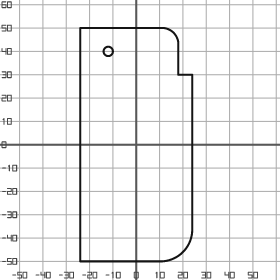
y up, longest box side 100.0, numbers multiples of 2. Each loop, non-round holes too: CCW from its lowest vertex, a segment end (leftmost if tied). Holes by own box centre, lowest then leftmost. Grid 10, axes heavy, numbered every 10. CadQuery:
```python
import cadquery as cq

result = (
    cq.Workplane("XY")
    .moveTo(-24.0, -50.0)
    .lineTo(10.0, -50.0)
    .threePointArc((20.0, -46.0), (24.0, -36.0))
    .lineTo(24.0, 30.0)
    .lineTo(18.0, 30.0)
    .lineTo(18.0, 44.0)
    .threePointArc((16.0, 48.0), (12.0, 50.0))
    .lineTo(-24.0, 50.0)
    .close()
    .moveTo(-12.0, 40.0)
    .circle(2.0)
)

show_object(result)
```